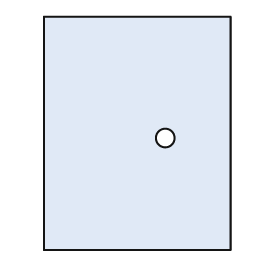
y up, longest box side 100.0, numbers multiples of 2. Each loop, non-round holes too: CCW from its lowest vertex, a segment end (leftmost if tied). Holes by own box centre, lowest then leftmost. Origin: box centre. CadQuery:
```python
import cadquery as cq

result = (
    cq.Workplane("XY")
    .moveTo(-40.0, -50.0)
    .lineTo(40.0, -50.0)
    .lineTo(40.0, 50.0)
    .lineTo(-40.0, 50.0)
    .close()
    .moveTo(12.0, -2.0)
    .circle(4.0)
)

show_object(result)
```